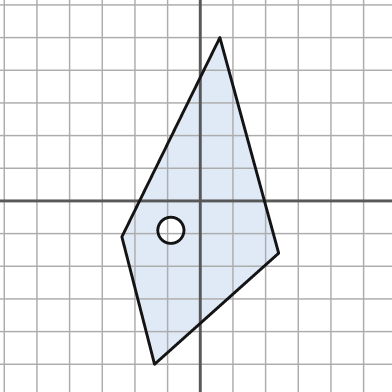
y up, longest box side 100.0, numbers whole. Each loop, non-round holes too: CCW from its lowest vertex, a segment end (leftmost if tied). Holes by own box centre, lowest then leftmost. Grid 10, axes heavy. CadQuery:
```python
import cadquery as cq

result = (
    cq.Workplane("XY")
    .moveTo(-14.0, -50.0)
    .lineTo(24.0, -16.0)
    .lineTo(6.0, 50.0)
    .lineTo(-24.0, -11.0)
    .close()
    .moveTo(-9.0, -9.0)
    .circle(4.0)
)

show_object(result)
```